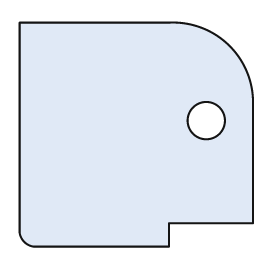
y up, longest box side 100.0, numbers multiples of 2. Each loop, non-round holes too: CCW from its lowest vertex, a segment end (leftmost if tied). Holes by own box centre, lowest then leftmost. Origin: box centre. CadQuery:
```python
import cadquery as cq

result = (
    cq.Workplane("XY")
    .moveTo(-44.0, -48.0)
    .lineTo(14.0, -48.0)
    .lineTo(14.0, -38.0)
    .lineTo(50.0, -38.0)
    .lineTo(50.0, 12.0)
    .threePointArc((40.0, 38.0), (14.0, 48.0))
    .lineTo(-50.0, 48.0)
    .lineTo(-50.0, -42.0)
    .threePointArc((-48.0, -46.0), (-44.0, -48.0))
    .close()
    .moveTo(30.0, 6.0)
    .circle(8.0)
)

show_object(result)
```